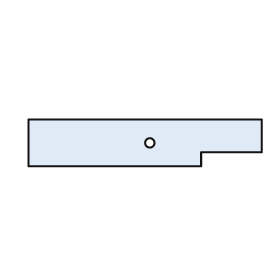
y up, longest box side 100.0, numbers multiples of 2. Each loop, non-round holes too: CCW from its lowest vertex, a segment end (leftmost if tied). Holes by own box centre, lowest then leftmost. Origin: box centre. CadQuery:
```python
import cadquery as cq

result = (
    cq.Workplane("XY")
    .moveTo(-50.0, -10.0)
    .lineTo(24.0, -10.0)
    .lineTo(24.0, -4.0)
    .lineTo(50.0, -4.0)
    .lineTo(50.0, 10.0)
    .lineTo(-50.0, 10.0)
    .close()
    .moveTo(2.0, 0.0)
    .circle(2.0)
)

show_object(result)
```